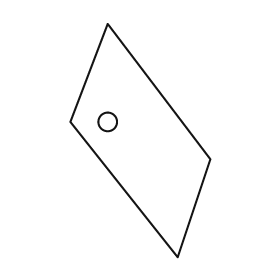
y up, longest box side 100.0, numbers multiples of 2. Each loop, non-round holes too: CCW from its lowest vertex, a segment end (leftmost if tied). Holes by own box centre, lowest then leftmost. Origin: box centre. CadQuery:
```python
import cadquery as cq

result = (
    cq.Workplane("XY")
    .moveTo(16.0, -50.0)
    .lineTo(30.0, -8.0)
    .lineTo(-14.0, 50.0)
    .lineTo(-30.0, 8.0)
    .close()
    .moveTo(-14.0, 8.0)
    .circle(4.0)
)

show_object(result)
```